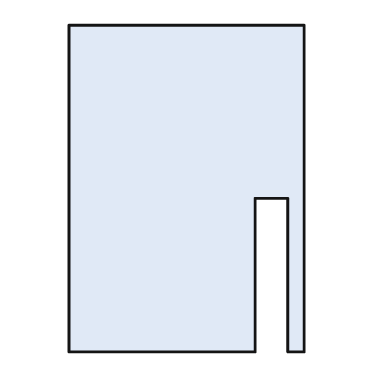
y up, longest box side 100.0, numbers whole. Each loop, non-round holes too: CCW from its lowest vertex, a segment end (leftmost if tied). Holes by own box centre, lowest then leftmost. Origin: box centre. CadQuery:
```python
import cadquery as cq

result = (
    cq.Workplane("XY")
    .moveTo(-36.0, -50.0)
    .lineTo(21.0, -50.0)
    .lineTo(21.0, -3.0)
    .lineTo(31.0, -3.0)
    .lineTo(31.0, -50.0)
    .lineTo(36.0, -50.0)
    .lineTo(36.0, 50.0)
    .lineTo(-36.0, 50.0)
    .close()
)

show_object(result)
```